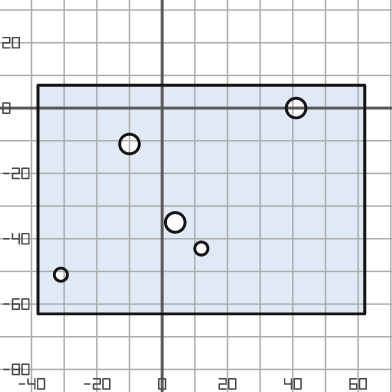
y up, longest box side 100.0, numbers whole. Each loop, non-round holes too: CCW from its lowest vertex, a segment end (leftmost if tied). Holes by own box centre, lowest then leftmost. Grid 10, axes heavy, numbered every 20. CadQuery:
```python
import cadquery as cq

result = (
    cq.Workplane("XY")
    .moveTo(-38.0, -63.0)
    .lineTo(62.0, -63.0)
    .lineTo(62.0, 7.0)
    .lineTo(-38.0, 7.0)
    .close()
    .moveTo(-31.0, -51.0)
    .circle(2.0)
    .moveTo(12.0, -43.0)
    .circle(2.0)
    .moveTo(4.0, -35.0)
    .circle(3.0)
    .moveTo(-10.0, -11.0)
    .circle(3.0)
    .moveTo(41.0, 0.0)
    .circle(3.0)
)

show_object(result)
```